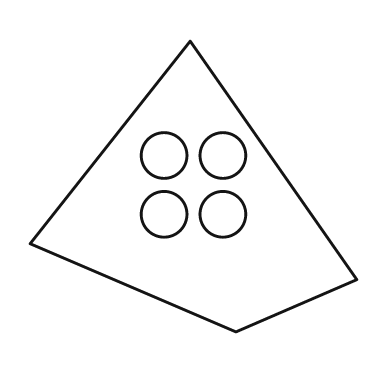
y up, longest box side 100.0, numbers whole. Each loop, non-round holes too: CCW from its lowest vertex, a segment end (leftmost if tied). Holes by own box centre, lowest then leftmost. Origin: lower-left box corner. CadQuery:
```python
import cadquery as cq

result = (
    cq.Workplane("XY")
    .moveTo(63.0, 0.0)
    .lineTo(100.0, 16.0)
    .lineTo(49.0, 89.0)
    .lineTo(0.0, 27.0)
    .close()
    .moveTo(41.0, 36.0)
    .circle(7.0)
    .moveTo(59.0, 36.0)
    .circle(7.0)
    .moveTo(41.0, 54.0)
    .circle(7.0)
    .moveTo(59.0, 54.0)
    .circle(7.0)
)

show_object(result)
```